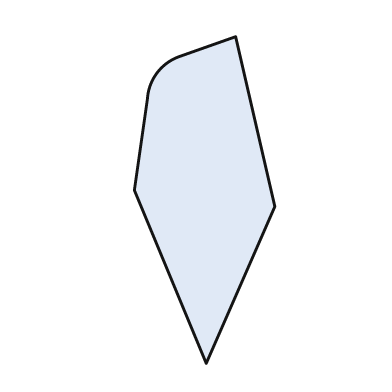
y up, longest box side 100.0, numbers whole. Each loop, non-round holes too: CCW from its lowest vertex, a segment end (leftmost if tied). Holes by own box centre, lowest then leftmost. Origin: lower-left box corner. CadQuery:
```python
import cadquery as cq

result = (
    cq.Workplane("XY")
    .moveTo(22.0, 0.0)
    .lineTo(43.0, 48.0)
    .lineTo(31.0, 100.0)
    .lineTo(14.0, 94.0)
    .threePointArc((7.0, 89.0), (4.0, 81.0))
    .lineTo(0.0, 53.0)
    .close()
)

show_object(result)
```